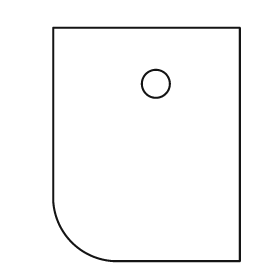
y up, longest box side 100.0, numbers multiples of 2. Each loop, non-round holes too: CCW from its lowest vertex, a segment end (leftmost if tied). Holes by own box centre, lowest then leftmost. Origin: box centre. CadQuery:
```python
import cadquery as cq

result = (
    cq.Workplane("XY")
    .moveTo(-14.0, -50.0)
    .lineTo(40.0, -50.0)
    .lineTo(40.0, 50.0)
    .lineTo(-40.0, 50.0)
    .lineTo(-40.0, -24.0)
    .threePointArc((-32.0, -42.0), (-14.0, -50.0))
    .close()
    .moveTo(4.0, 26.0)
    .circle(6.0)
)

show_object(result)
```